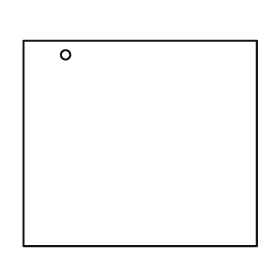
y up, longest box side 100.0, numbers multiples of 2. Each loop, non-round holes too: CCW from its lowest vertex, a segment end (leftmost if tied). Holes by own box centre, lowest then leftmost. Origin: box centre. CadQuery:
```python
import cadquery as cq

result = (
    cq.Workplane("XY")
    .moveTo(-50.0, -44.0)
    .lineTo(50.0, -44.0)
    .lineTo(50.0, 44.0)
    .lineTo(-50.0, 44.0)
    .close()
    .moveTo(-32.0, 38.0)
    .circle(2.0)
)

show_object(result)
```